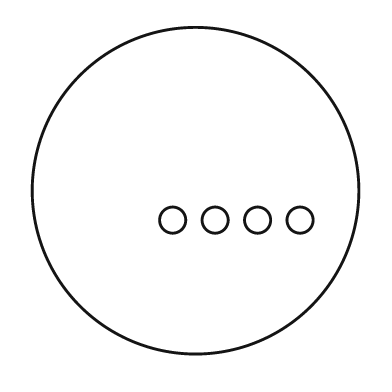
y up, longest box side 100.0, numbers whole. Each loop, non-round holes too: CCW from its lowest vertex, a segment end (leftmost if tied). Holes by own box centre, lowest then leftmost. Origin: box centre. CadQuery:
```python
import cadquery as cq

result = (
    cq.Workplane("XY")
    .moveTo(0.0, 0.0)
    .circle(50.0)
    .moveTo(-7.0, -9.0)
    .circle(4.0)
    .moveTo(6.0, -9.0)
    .circle(4.0)
    .moveTo(19.0, -9.0)
    .circle(4.0)
    .moveTo(32.0, -9.0)
    .circle(4.0)
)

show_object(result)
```